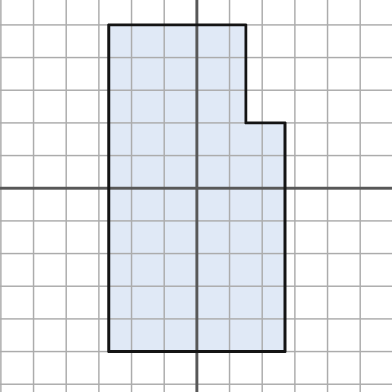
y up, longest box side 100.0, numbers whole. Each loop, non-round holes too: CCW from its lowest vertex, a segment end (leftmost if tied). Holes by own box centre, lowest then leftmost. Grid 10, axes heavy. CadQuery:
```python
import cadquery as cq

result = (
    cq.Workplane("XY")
    .moveTo(-27.0, -50.0)
    .lineTo(27.0, -50.0)
    .lineTo(27.0, 20.0)
    .lineTo(15.0, 20.0)
    .lineTo(15.0, 50.0)
    .lineTo(-27.0, 50.0)
    .close()
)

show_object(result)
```